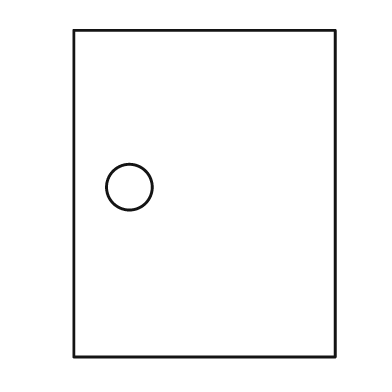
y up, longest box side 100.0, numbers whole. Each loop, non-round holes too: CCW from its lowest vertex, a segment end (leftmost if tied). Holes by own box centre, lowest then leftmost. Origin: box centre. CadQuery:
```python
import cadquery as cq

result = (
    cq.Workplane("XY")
    .moveTo(-40.0, -50.0)
    .lineTo(40.0, -50.0)
    .lineTo(40.0, 50.0)
    .lineTo(-40.0, 50.0)
    .close()
    .moveTo(-23.0, 2.0)
    .circle(7.0)
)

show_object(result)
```